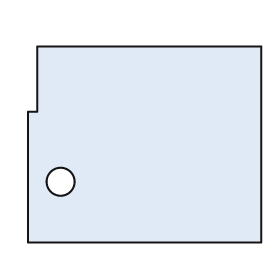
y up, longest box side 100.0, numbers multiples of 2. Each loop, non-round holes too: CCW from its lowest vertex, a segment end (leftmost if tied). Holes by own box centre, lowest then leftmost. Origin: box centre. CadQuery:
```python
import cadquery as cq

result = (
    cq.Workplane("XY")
    .moveTo(-50.0, -42.0)
    .lineTo(50.0, -42.0)
    .lineTo(50.0, 42.0)
    .lineTo(-46.0, 42.0)
    .lineTo(-46.0, 14.0)
    .lineTo(-50.0, 14.0)
    .close()
    .moveTo(-36.0, -16.0)
    .circle(6.0)
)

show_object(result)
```